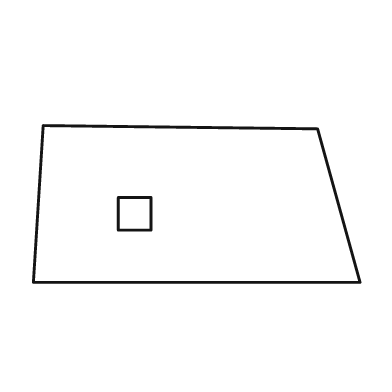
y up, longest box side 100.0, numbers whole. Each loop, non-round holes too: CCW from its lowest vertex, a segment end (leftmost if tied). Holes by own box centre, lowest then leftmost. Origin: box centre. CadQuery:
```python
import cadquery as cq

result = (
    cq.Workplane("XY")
    .moveTo(-50.0, -24.0)
    .lineTo(50.0, -24.0)
    .lineTo(37.0, 23.0)
    .lineTo(-47.0, 24.0)
    .close()
    .moveTo(-24.0, -8.0)
    .lineTo(-14.0, -8.0)
    .lineTo(-14.0, 2.0)
    .lineTo(-24.0, 2.0)
    .close()
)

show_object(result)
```